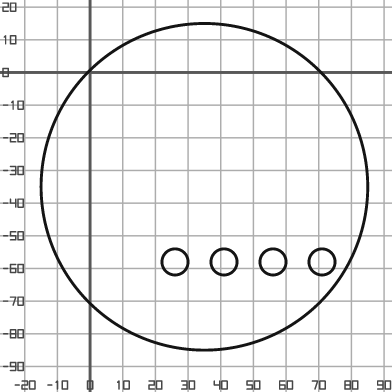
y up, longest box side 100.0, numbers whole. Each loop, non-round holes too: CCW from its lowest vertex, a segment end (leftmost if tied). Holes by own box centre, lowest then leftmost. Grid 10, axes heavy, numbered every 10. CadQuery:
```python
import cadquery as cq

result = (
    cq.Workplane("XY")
    .moveTo(35.0, -35.0)
    .circle(50.0)
    .moveTo(26.0, -58.0)
    .circle(4.0)
    .moveTo(41.0, -58.0)
    .circle(4.0)
    .moveTo(56.0, -58.0)
    .circle(4.0)
    .moveTo(71.0, -58.0)
    .circle(4.0)
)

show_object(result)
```